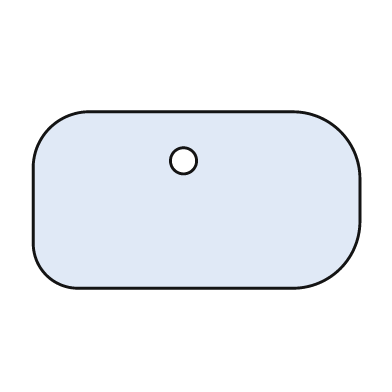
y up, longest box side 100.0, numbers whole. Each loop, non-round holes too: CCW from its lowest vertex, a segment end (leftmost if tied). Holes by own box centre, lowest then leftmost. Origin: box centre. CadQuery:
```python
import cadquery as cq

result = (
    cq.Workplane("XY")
    .moveTo(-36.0, -27.0)
    .lineTo(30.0, -27.0)
    .threePointArc((44.0, -21.0), (50.0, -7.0))
    .lineTo(50.0, 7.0)
    .threePointArc((44.0, 21.0), (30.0, 27.0))
    .lineTo(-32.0, 27.0)
    .threePointArc((-45.0, 22.0), (-50.0, 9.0))
    .lineTo(-50.0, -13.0)
    .threePointArc((-46.0, -23.0), (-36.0, -27.0))
    .close()
    .moveTo(-4.0, 12.0)
    .circle(4.0)
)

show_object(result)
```